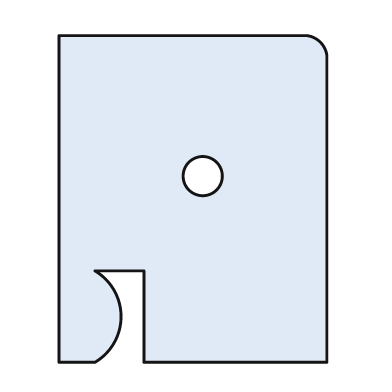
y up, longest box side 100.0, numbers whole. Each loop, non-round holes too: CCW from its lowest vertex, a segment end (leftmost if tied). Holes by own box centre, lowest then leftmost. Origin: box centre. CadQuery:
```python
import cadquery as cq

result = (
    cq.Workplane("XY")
    .moveTo(-41.0, -50.0)
    .lineTo(-30.0, -50.0)
    .threePointArc((-22.0, -36.0), (-30.0, -22.0))
    .lineTo(-15.0, -22.0)
    .lineTo(-15.0, -50.0)
    .lineTo(41.0, -50.0)
    .lineTo(41.0, 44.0)
    .threePointArc((39.0, 48.0), (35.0, 50.0))
    .lineTo(-41.0, 50.0)
    .close()
    .moveTo(3.0, 7.0)
    .circle(6.0)
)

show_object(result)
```